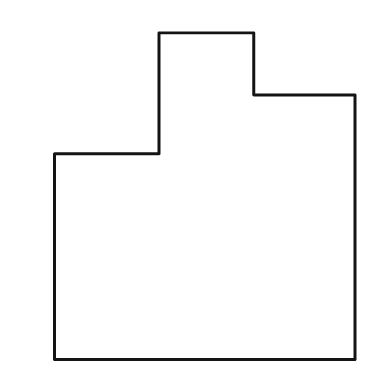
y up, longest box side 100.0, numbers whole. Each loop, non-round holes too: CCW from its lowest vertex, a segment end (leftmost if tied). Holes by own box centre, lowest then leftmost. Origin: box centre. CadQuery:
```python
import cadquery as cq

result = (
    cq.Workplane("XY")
    .moveTo(-46.0, -50.0)
    .lineTo(46.0, -50.0)
    .lineTo(46.0, 31.0)
    .lineTo(15.0, 31.0)
    .lineTo(15.0, 50.0)
    .lineTo(-14.0, 50.0)
    .lineTo(-14.0, 13.0)
    .lineTo(-46.0, 13.0)
    .close()
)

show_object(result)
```